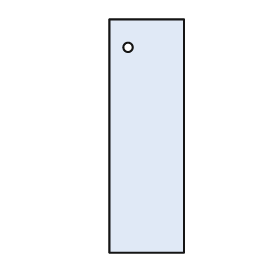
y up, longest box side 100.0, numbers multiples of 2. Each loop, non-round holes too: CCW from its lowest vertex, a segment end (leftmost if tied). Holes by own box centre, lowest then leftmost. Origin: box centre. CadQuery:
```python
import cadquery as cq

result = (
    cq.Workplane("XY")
    .moveTo(-16.0, -50.0)
    .lineTo(16.0, -50.0)
    .lineTo(16.0, 50.0)
    .lineTo(-16.0, 50.0)
    .close()
    .moveTo(-8.0, 38.0)
    .circle(2.0)
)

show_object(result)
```